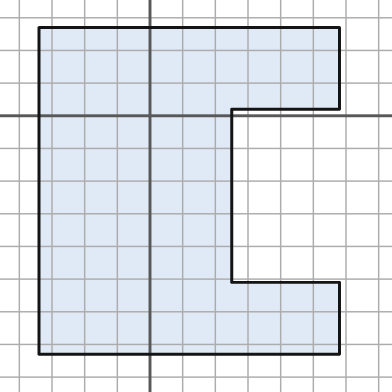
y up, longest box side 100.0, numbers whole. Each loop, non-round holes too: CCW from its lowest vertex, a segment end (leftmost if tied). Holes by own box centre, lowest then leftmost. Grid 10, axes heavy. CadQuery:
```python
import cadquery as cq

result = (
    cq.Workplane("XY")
    .moveTo(-34.0, -73.0)
    .lineTo(58.0, -73.0)
    .lineTo(58.0, -51.0)
    .lineTo(25.0, -51.0)
    .lineTo(25.0, 2.0)
    .lineTo(58.0, 2.0)
    .lineTo(58.0, 27.0)
    .lineTo(-34.0, 27.0)
    .close()
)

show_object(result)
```